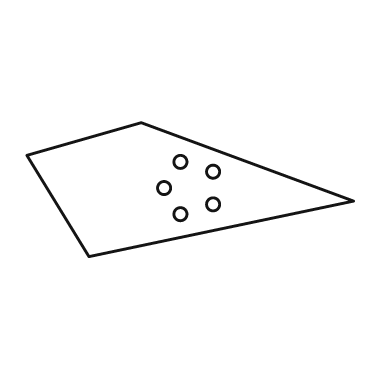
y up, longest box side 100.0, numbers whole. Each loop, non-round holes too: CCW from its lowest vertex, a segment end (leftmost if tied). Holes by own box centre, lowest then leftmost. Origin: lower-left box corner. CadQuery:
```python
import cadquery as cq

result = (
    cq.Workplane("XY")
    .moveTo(19.0, 0.0)
    .lineTo(100.0, 17.0)
    .lineTo(35.0, 41.0)
    .lineTo(0.0, 31.0)
    .close()
    .moveTo(47.0, 13.0)
    .circle(2.0)
    .moveTo(57.0, 16.0)
    .circle(2.0)
    .moveTo(42.0, 21.0)
    .circle(2.0)
    .moveTo(57.0, 26.0)
    .circle(2.0)
    .moveTo(47.0, 29.0)
    .circle(2.0)
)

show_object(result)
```